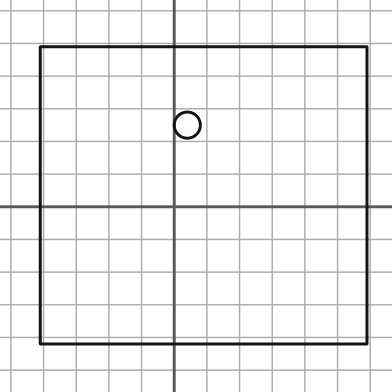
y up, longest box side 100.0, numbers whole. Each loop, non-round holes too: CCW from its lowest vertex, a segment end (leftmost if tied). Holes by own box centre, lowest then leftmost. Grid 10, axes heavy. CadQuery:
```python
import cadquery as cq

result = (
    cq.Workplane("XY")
    .moveTo(-41.0, -42.0)
    .lineTo(59.0, -42.0)
    .lineTo(59.0, 49.0)
    .lineTo(-41.0, 49.0)
    .close()
    .moveTo(4.0, 25.0)
    .circle(4.0)
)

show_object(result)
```